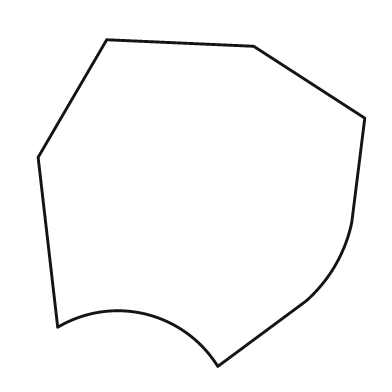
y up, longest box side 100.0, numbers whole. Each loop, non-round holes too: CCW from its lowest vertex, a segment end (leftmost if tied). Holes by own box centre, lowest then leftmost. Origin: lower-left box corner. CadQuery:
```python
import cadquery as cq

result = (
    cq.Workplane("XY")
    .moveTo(55.0, 0.0)
    .lineTo(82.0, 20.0)
    .threePointArc((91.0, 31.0), (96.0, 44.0))
    .lineTo(100.0, 76.0)
    .lineTo(66.0, 98.0)
    .lineTo(21.0, 100.0)
    .lineTo(0.0, 64.0)
    .lineTo(6.0, 12.0)
    .threePointArc((33.0, 16.0), (55.0, 0.0))
    .close()
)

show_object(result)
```